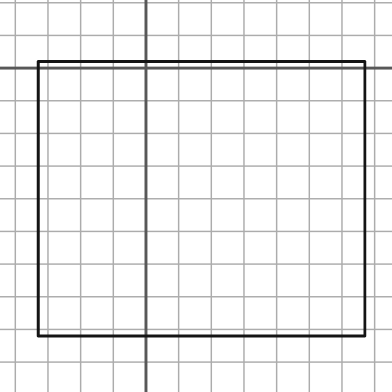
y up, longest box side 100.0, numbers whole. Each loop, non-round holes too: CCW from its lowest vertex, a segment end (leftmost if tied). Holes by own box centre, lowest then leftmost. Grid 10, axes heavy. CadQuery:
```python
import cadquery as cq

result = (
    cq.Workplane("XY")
    .moveTo(-33.0, -82.0)
    .lineTo(67.0, -82.0)
    .lineTo(67.0, 2.0)
    .lineTo(-33.0, 2.0)
    .close()
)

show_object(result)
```